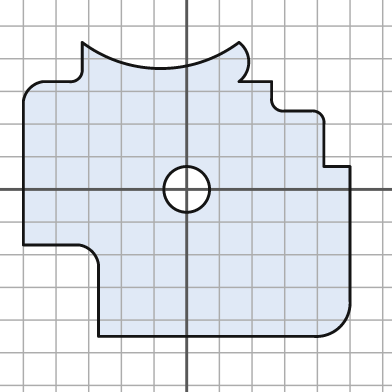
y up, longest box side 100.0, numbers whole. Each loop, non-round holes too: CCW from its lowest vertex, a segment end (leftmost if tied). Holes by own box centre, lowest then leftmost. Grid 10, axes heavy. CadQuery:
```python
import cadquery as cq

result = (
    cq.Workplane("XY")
    .moveTo(-27.0, -45.0)
    .lineTo(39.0, -45.0)
    .threePointArc((47.0, -42.0), (50.0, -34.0))
    .lineTo(50.0, 7.0)
    .lineTo(42.0, 7.0)
    .lineTo(42.0, 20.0)
    .threePointArc((41.0, 23.0), (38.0, 24.0))
    .lineTo(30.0, 24.0)
    .threePointArc((27.0, 25.0), (26.0, 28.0))
    .lineTo(26.0, 33.0)
    .lineTo(16.0, 33.0)
    .threePointArc((19.0, 39.0), (16.0, 45.0))
    .threePointArc((-8.0, 37.0), (-32.0, 45.0))
    .lineTo(-32.0, 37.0)
    .threePointArc((-33.0, 34.0), (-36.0, 33.0))
    .lineTo(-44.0, 33.0)
    .threePointArc((-48.0, 31.0), (-50.0, 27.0))
    .lineTo(-50.0, -17.0)
    .lineTo(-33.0, -17.0)
    .threePointArc((-29.0, -19.0), (-27.0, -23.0))
    .close()
    .moveTo(0.0, 0.0)
    .circle(7.0)
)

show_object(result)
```